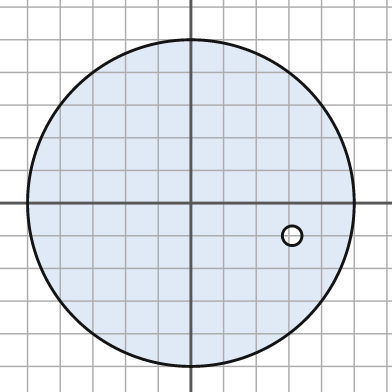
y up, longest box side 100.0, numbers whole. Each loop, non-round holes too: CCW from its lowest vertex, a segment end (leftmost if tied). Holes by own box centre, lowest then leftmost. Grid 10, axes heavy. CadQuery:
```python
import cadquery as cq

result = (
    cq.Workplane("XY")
    .moveTo(0.0, 0.0)
    .circle(50.0)
    .moveTo(31.0, -10.0)
    .circle(3.0)
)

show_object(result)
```